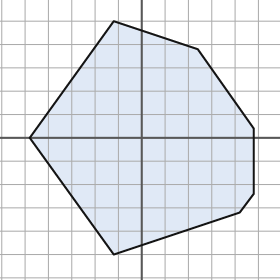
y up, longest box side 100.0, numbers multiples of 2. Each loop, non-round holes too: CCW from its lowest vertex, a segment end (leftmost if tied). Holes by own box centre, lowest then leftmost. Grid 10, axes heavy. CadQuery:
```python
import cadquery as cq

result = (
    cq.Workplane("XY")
    .moveTo(-12.0, -50.0)
    .lineTo(42.0, -32.0)
    .lineTo(48.0, -24.0)
    .lineTo(48.0, 4.0)
    .lineTo(24.0, 38.0)
    .lineTo(-12.0, 50.0)
    .lineTo(-48.0, 0.0)
    .close()
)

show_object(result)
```